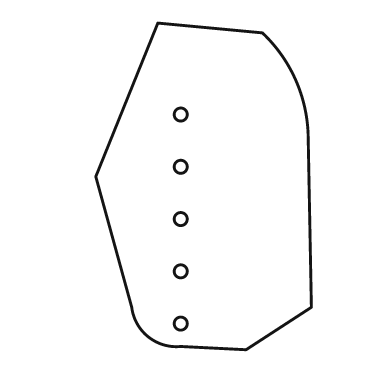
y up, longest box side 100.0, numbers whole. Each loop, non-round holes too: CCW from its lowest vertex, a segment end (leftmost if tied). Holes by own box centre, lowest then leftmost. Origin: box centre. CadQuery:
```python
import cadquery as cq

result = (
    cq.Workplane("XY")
    .moveTo(13.0, -50.0)
    .lineTo(33.0, -37.0)
    .lineTo(32.0, 16.0)
    .threePointArc((28.0, 33.0), (18.0, 47.0))
    .lineTo(-14.0, 50.0)
    .lineTo(-33.0, 3.0)
    .lineTo(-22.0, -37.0)
    .threePointArc((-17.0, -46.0), (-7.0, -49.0))
    .close()
    .moveTo(-7.0, -42.0)
    .circle(2.0)
    .moveTo(-7.0, -26.0)
    .circle(2.0)
    .moveTo(-7.0, -10.0)
    .circle(2.0)
    .moveTo(-7.0, 6.0)
    .circle(2.0)
    .moveTo(-7.0, 22.0)
    .circle(2.0)
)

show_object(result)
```